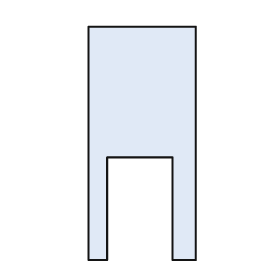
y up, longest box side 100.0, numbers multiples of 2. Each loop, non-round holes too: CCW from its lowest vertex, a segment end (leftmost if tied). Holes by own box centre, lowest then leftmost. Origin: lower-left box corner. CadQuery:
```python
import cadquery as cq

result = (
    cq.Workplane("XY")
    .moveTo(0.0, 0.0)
    .lineTo(8.0, 0.0)
    .lineTo(8.0, 44.0)
    .lineTo(36.0, 44.0)
    .lineTo(36.0, 0.0)
    .lineTo(46.0, 0.0)
    .lineTo(46.0, 100.0)
    .lineTo(0.0, 100.0)
    .close()
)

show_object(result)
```